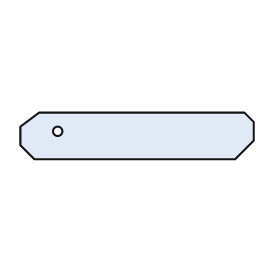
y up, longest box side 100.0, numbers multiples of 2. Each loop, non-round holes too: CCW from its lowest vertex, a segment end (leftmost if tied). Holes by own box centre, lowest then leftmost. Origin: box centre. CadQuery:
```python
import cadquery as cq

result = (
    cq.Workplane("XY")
    .moveTo(-44.0, -10.0)
    .lineTo(42.0, -10.0)
    .lineTo(50.0, -2.0)
    .lineTo(50.0, 6.0)
    .lineTo(46.0, 10.0)
    .lineTo(-42.0, 10.0)
    .lineTo(-50.0, 4.0)
    .lineTo(-50.0, -4.0)
    .close()
    .moveTo(-34.0, 2.0)
    .circle(2.0)
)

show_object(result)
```